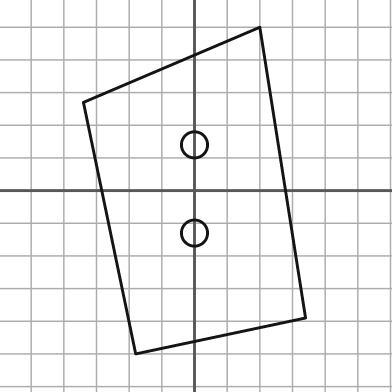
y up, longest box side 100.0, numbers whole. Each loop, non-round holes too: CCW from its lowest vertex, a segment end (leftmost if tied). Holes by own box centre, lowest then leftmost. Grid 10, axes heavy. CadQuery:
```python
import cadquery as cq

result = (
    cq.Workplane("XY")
    .moveTo(-18.0, -50.0)
    .lineTo(34.0, -39.0)
    .lineTo(20.0, 50.0)
    .lineTo(-34.0, 27.0)
    .close()
    .moveTo(0.0, -13.0)
    .circle(4.0)
    .moveTo(0.0, 14.0)
    .circle(4.0)
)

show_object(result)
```